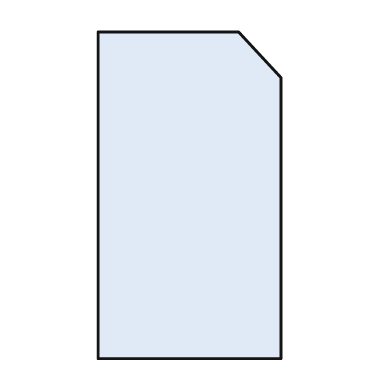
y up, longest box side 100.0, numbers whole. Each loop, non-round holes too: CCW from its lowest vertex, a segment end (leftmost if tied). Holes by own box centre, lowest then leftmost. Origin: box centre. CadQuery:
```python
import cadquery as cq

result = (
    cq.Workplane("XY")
    .moveTo(-28.0, -50.0)
    .lineTo(28.0, -50.0)
    .lineTo(28.0, 36.0)
    .lineTo(15.0, 50.0)
    .lineTo(-28.0, 50.0)
    .close()
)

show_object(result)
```